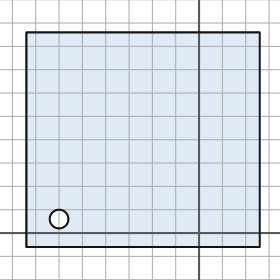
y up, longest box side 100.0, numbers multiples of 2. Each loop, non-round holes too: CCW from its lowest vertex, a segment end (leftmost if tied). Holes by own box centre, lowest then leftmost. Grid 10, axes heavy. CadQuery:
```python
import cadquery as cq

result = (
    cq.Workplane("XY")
    .moveTo(-74.0, -6.0)
    .lineTo(26.0, -6.0)
    .lineTo(26.0, 86.0)
    .lineTo(-74.0, 86.0)
    .close()
    .moveTo(-60.0, 6.0)
    .circle(4.0)
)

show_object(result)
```